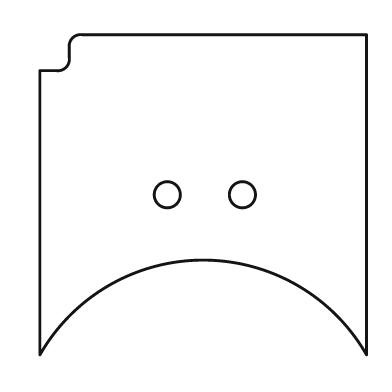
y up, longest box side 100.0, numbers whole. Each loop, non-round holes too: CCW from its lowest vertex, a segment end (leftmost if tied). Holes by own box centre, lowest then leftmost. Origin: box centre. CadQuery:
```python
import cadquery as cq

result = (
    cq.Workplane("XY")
    .moveTo(-50.0, -49.0)
    .threePointArc((0.0, -20.0), (50.0, -49.0))
    .lineTo(50.0, 49.0)
    .lineTo(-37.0, 49.0)
    .threePointArc((-40.0, 48.0), (-41.0, 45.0))
    .lineTo(-41.0, 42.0)
    .threePointArc((-42.0, 39.0), (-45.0, 38.0))
    .lineTo(-50.0, 38.0)
    .close()
    .moveTo(-11.0, 0.0)
    .circle(4.0)
    .moveTo(12.0, 0.0)
    .circle(4.0)
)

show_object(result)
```